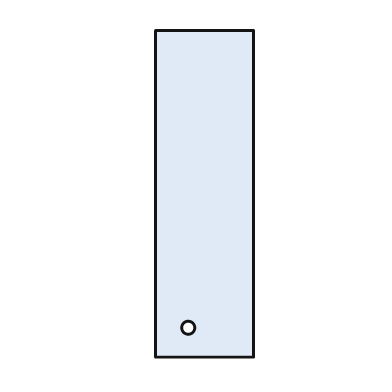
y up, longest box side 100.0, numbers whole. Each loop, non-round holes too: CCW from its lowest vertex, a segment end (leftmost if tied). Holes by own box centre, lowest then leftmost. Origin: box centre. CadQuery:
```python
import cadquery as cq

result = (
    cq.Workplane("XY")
    .moveTo(-15.0, -50.0)
    .lineTo(15.0, -50.0)
    .lineTo(15.0, 50.0)
    .lineTo(-15.0, 50.0)
    .close()
    .moveTo(-5.0, -41.0)
    .circle(2.0)
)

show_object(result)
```